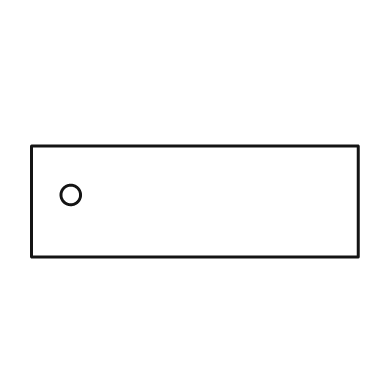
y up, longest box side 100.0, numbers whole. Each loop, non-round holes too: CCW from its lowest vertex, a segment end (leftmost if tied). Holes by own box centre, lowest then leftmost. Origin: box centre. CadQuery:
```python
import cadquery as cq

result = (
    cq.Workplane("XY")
    .moveTo(-50.0, -17.0)
    .lineTo(50.0, -17.0)
    .lineTo(50.0, 17.0)
    .lineTo(-50.0, 17.0)
    .close()
    .moveTo(-38.0, 2.0)
    .circle(3.0)
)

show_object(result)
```